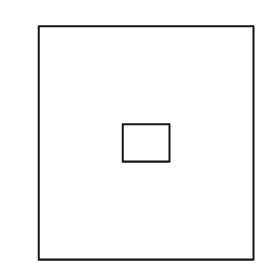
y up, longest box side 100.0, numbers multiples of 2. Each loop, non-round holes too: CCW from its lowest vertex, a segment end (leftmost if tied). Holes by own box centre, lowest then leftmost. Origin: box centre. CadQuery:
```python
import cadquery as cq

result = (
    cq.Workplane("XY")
    .moveTo(-46.0, -50.0)
    .lineTo(46.0, -50.0)
    .lineTo(46.0, 50.0)
    .lineTo(-46.0, 50.0)
    .close()
    .moveTo(-10.0, -8.0)
    .lineTo(10.0, -8.0)
    .lineTo(10.0, 8.0)
    .lineTo(-10.0, 8.0)
    .close()
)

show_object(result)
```